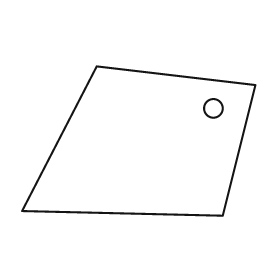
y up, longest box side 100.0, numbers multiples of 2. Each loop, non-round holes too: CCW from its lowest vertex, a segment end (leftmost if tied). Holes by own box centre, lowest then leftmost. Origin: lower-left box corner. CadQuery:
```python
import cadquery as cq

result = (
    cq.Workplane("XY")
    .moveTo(86.0, 0.0)
    .lineTo(100.0, 56.0)
    .lineTo(32.0, 64.0)
    .lineTo(0.0, 2.0)
    .close()
    .moveTo(82.0, 46.0)
    .circle(4.0)
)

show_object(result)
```